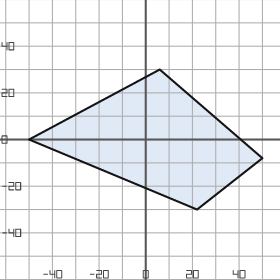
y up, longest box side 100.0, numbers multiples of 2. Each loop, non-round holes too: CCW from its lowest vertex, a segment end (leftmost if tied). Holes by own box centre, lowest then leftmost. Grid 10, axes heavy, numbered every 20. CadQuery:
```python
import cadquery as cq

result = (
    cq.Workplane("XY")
    .moveTo(22.0, -30.0)
    .lineTo(50.0, -8.0)
    .lineTo(6.0, 30.0)
    .lineTo(-50.0, 0.0)
    .close()
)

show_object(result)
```